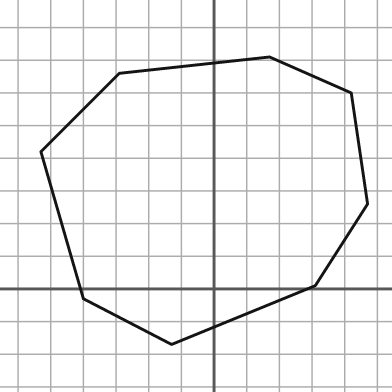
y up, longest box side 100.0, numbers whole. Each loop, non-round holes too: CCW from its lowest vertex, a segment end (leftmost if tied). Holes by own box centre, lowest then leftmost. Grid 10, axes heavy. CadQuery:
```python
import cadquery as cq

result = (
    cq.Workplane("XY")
    .moveTo(-13.0, -17.0)
    .lineTo(31.0, 1.0)
    .lineTo(47.0, 26.0)
    .lineTo(42.0, 60.0)
    .lineTo(17.0, 71.0)
    .lineTo(-29.0, 66.0)
    .lineTo(-53.0, 42.0)
    .lineTo(-40.0, -3.0)
    .close()
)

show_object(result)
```